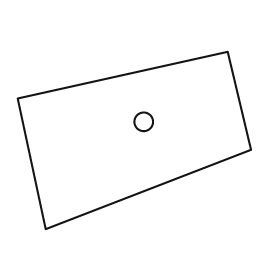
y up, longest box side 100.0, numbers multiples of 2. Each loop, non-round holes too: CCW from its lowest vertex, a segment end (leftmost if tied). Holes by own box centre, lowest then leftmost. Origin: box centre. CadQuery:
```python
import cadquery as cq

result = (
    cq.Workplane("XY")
    .moveTo(-38.0, -38.0)
    .lineTo(50.0, -4.0)
    .lineTo(40.0, 38.0)
    .lineTo(-50.0, 18.0)
    .close()
    .moveTo(4.0, 8.0)
    .circle(4.0)
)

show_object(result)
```